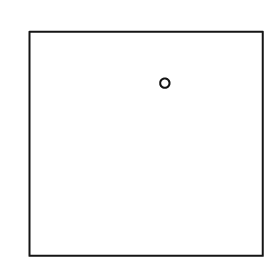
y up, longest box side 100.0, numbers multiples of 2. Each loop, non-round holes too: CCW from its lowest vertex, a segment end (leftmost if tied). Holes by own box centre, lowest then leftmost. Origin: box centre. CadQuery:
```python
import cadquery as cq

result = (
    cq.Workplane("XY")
    .moveTo(-50.0, -48.0)
    .lineTo(50.0, -48.0)
    .lineTo(50.0, 48.0)
    .lineTo(-50.0, 48.0)
    .close()
    .moveTo(8.0, 26.0)
    .circle(2.0)
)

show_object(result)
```